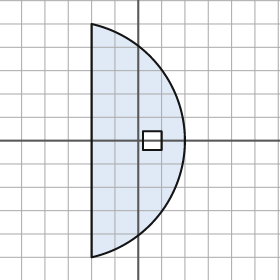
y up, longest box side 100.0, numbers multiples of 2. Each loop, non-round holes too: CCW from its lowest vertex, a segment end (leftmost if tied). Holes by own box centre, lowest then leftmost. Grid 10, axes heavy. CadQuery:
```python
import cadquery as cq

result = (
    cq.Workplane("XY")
    .moveTo(-20.0, -50.0)
    .threePointArc((20.0, 0.0), (-20.0, 50.0))
    .close()
    .moveTo(2.0, -4.0)
    .lineTo(10.0, -4.0)
    .lineTo(10.0, 4.0)
    .lineTo(2.0, 4.0)
    .close()
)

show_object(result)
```